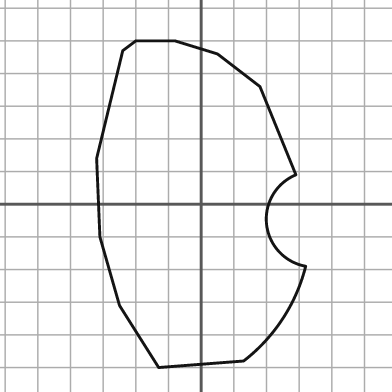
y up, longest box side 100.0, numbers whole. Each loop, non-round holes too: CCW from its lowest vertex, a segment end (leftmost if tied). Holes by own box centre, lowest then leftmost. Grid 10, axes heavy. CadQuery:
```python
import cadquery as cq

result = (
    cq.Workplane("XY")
    .moveTo(-13.0, -50.0)
    .lineTo(13.0, -48.0)
    .threePointArc((25.0, -35.0), (32.0, -19.0))
    .threePointArc((20.0, -6.0), (29.0, 9.0))
    .lineTo(18.0, 36.0)
    .lineTo(5.0, 46.0)
    .lineTo(-8.0, 50.0)
    .lineTo(-20.0, 50.0)
    .lineTo(-24.0, 47.0)
    .lineTo(-32.0, 14.0)
    .lineTo(-31.0, -10.0)
    .lineTo(-25.0, -31.0)
    .close()
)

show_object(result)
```